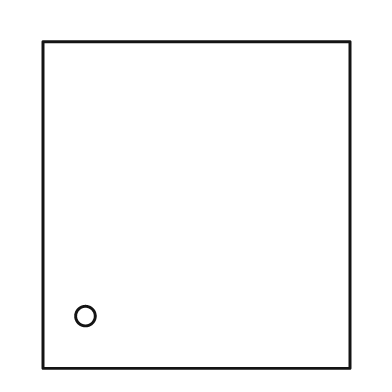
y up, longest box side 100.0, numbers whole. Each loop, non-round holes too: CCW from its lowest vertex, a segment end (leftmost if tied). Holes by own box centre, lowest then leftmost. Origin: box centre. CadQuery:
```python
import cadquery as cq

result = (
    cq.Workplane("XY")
    .moveTo(-47.0, -50.0)
    .lineTo(47.0, -50.0)
    .lineTo(47.0, 50.0)
    .lineTo(-47.0, 50.0)
    .close()
    .moveTo(-34.0, -34.0)
    .circle(3.0)
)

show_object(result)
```